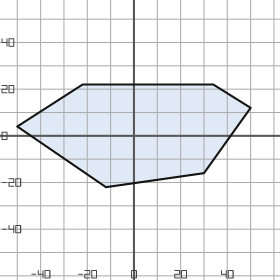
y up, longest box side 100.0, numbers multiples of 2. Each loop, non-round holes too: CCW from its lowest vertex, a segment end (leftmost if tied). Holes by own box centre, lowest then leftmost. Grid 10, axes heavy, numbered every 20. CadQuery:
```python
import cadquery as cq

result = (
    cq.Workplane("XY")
    .moveTo(-12.0, -22.0)
    .lineTo(30.0, -16.0)
    .lineTo(50.0, 12.0)
    .lineTo(34.0, 22.0)
    .lineTo(-22.0, 22.0)
    .lineTo(-50.0, 4.0)
    .close()
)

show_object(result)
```